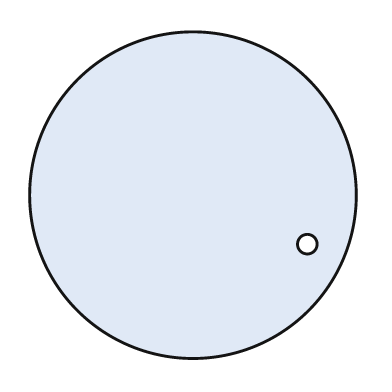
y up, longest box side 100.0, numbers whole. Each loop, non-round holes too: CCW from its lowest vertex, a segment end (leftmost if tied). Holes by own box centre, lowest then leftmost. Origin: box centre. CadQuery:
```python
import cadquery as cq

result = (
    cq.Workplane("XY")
    .moveTo(0.0, 0.0)
    .circle(50.0)
    .moveTo(35.0, -15.0)
    .circle(3.0)
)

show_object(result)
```